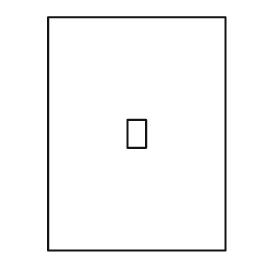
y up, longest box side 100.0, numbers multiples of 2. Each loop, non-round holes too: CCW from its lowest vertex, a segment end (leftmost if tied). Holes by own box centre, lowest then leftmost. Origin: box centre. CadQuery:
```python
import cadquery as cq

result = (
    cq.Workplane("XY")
    .moveTo(-38.0, -50.0)
    .lineTo(38.0, -50.0)
    .lineTo(38.0, 50.0)
    .lineTo(-38.0, 50.0)
    .close()
    .moveTo(-4.0, -6.0)
    .lineTo(4.0, -6.0)
    .lineTo(4.0, 6.0)
    .lineTo(-4.0, 6.0)
    .close()
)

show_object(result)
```